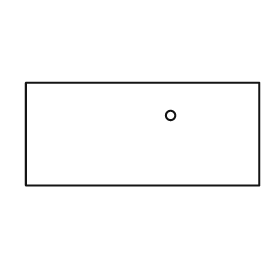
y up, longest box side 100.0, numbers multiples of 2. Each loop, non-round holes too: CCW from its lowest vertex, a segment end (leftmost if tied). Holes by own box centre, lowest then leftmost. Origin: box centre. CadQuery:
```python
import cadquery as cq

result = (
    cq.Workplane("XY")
    .moveTo(-50.0, -22.0)
    .lineTo(50.0, -22.0)
    .lineTo(50.0, 22.0)
    .lineTo(-50.0, 22.0)
    .close()
    .moveTo(12.0, 8.0)
    .circle(2.0)
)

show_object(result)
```